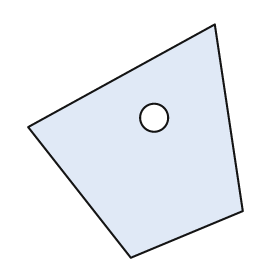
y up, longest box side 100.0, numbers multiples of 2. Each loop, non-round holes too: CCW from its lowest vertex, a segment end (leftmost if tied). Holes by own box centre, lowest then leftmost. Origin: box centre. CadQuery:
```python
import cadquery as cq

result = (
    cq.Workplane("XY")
    .moveTo(-2.0, -50.0)
    .lineTo(46.0, -30.0)
    .lineTo(34.0, 50.0)
    .lineTo(-46.0, 6.0)
    .close()
    .moveTo(8.0, 10.0)
    .circle(6.0)
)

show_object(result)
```